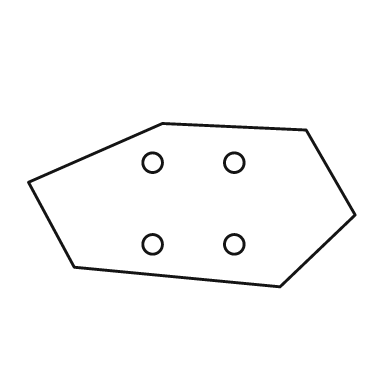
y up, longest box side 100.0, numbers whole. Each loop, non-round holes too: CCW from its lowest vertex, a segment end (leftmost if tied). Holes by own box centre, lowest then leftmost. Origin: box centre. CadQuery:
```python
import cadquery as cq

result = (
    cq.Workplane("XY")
    .moveTo(27.0, -25.0)
    .lineTo(50.0, -3.0)
    .lineTo(35.0, 23.0)
    .lineTo(-9.0, 25.0)
    .lineTo(-50.0, 7.0)
    .lineTo(-36.0, -19.0)
    .close()
    .moveTo(-12.0, -12.0)
    .circle(3.0)
    .moveTo(13.0, -12.0)
    .circle(3.0)
    .moveTo(-12.0, 13.0)
    .circle(3.0)
    .moveTo(13.0, 13.0)
    .circle(3.0)
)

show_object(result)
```